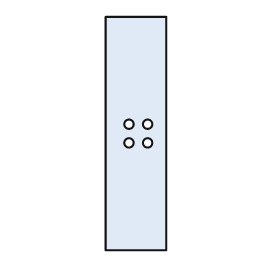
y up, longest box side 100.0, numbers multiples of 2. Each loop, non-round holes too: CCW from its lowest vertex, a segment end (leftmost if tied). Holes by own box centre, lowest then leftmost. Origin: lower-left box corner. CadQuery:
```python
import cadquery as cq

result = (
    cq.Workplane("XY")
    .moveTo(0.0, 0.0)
    .lineTo(26.0, 0.0)
    .lineTo(26.0, 100.0)
    .lineTo(0.0, 100.0)
    .close()
    .moveTo(10.0, 46.0)
    .circle(2.0)
    .moveTo(18.0, 46.0)
    .circle(2.0)
    .moveTo(10.0, 54.0)
    .circle(2.0)
    .moveTo(18.0, 54.0)
    .circle(2.0)
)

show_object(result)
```